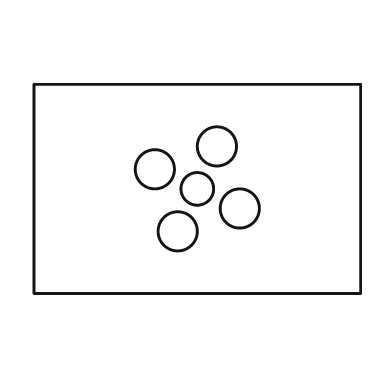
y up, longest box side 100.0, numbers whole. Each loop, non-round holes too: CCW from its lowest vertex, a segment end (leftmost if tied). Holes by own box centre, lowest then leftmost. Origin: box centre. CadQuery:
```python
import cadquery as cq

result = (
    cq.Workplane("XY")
    .moveTo(-50.0, -32.0)
    .lineTo(50.0, -32.0)
    .lineTo(50.0, 32.0)
    .lineTo(-50.0, 32.0)
    .close()
    .moveTo(-6.0, -13.0)
    .circle(6.0)
    .moveTo(13.0, -6.0)
    .circle(6.0)
    .moveTo(0.0, 0.0)
    .circle(5.0)
    .moveTo(-13.0, 6.0)
    .circle(6.0)
    .moveTo(6.0, 13.0)
    .circle(6.0)
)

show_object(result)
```